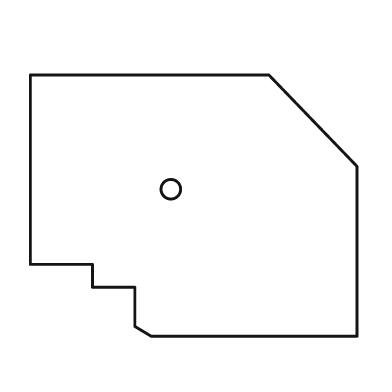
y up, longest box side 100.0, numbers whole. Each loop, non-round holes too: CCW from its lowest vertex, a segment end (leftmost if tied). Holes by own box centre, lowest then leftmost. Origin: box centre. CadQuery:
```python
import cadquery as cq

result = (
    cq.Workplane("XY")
    .moveTo(-13.0, -40.0)
    .lineTo(50.0, -40.0)
    .lineTo(50.0, 12.0)
    .lineTo(23.0, 40.0)
    .lineTo(-50.0, 40.0)
    .lineTo(-50.0, -18.0)
    .lineTo(-31.0, -18.0)
    .lineTo(-31.0, -25.0)
    .lineTo(-18.0, -25.0)
    .lineTo(-18.0, -37.0)
    .close()
    .moveTo(-7.0, 5.0)
    .circle(3.0)
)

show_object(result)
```